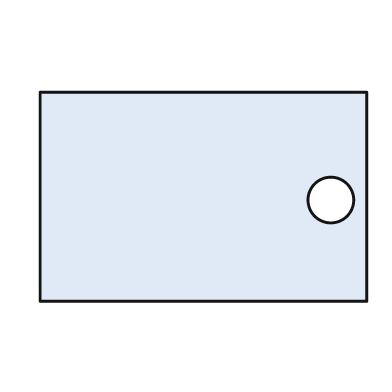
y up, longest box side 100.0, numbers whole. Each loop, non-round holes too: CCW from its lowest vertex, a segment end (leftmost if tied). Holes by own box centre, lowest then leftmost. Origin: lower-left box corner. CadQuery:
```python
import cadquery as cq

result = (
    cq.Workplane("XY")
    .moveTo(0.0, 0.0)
    .lineTo(100.0, 0.0)
    .lineTo(100.0, 64.0)
    .lineTo(0.0, 64.0)
    .close()
    .moveTo(89.0, 31.0)
    .circle(7.0)
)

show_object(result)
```